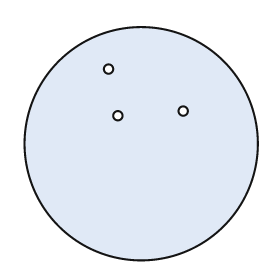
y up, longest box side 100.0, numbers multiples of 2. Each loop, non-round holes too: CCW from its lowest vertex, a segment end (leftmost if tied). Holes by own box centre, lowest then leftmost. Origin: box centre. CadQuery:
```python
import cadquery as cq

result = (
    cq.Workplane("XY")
    .moveTo(0.0, 0.0)
    .circle(50.0)
    .moveTo(-10.0, 12.0)
    .circle(2.0)
    .moveTo(18.0, 14.0)
    .circle(2.0)
    .moveTo(-14.0, 32.0)
    .circle(2.0)
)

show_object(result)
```